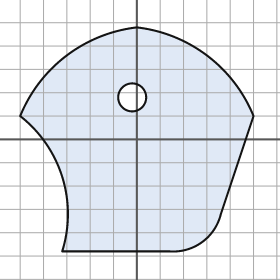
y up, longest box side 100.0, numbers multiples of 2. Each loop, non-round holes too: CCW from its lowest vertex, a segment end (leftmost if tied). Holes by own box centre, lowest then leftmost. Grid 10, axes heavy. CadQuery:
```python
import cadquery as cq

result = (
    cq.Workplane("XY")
    .moveTo(-32.0, -48.0)
    .lineTo(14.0, -48.0)
    .threePointArc((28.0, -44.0), (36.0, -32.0))
    .lineTo(50.0, 10.0)
    .threePointArc((30.0, 36.0), (0.0, 48.0))
    .threePointArc((-30.0, 36.0), (-50.0, 10.0))
    .threePointArc((-32.0, -16.0), (-32.0, -48.0))
    .close()
    .moveTo(-2.0, 18.0)
    .circle(6.0)
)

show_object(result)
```